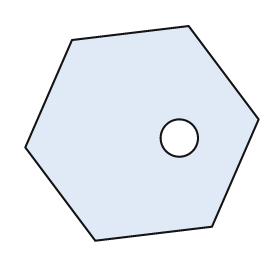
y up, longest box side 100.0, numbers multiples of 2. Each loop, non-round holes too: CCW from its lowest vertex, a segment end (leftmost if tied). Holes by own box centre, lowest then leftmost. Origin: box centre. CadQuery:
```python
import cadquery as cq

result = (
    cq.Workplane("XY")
    .moveTo(-20.0, -46.0)
    .lineTo(30.0, -40.0)
    .lineTo(50.0, 6.0)
    .lineTo(20.0, 46.0)
    .lineTo(-30.0, 40.0)
    .lineTo(-50.0, -6.0)
    .close()
    .moveTo(16.0, -2.0)
    .circle(8.0)
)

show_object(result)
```